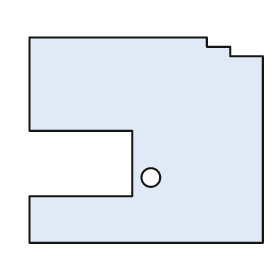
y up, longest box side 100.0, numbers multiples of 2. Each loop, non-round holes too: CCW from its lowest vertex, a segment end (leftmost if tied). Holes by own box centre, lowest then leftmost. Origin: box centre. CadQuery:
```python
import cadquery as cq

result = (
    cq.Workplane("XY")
    .moveTo(-50.0, -44.0)
    .lineTo(50.0, -44.0)
    .lineTo(50.0, 36.0)
    .lineTo(36.0, 36.0)
    .lineTo(36.0, 40.0)
    .lineTo(26.0, 40.0)
    .lineTo(26.0, 44.0)
    .lineTo(-50.0, 44.0)
    .lineTo(-50.0, 4.0)
    .lineTo(-6.0, 4.0)
    .lineTo(-6.0, -24.0)
    .lineTo(-50.0, -24.0)
    .close()
    .moveTo(2.0, -16.0)
    .circle(4.0)
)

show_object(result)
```